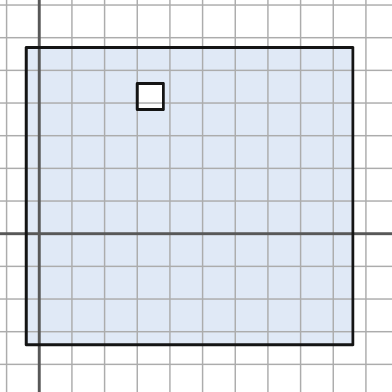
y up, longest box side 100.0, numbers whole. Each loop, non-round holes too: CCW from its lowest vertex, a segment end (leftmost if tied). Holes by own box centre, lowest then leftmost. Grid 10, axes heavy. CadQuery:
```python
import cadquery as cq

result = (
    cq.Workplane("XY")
    .moveTo(-4.0, -34.0)
    .lineTo(96.0, -34.0)
    .lineTo(96.0, 57.0)
    .lineTo(-4.0, 57.0)
    .close()
    .moveTo(30.0, 38.0)
    .lineTo(38.0, 38.0)
    .lineTo(38.0, 46.0)
    .lineTo(30.0, 46.0)
    .close()
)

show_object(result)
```